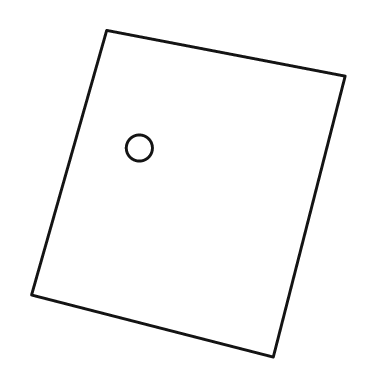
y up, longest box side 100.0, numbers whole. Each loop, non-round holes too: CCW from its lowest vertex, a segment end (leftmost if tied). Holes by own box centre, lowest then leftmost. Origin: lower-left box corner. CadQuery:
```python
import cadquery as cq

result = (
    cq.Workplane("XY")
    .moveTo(74.0, 0.0)
    .lineTo(96.0, 86.0)
    .lineTo(23.0, 100.0)
    .lineTo(0.0, 19.0)
    .close()
    .moveTo(33.0, 64.0)
    .circle(4.0)
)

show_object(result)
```